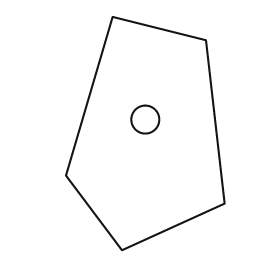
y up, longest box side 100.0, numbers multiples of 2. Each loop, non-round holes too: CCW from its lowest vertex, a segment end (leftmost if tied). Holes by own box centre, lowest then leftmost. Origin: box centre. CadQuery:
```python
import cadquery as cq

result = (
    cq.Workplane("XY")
    .moveTo(-10.0, -50.0)
    .lineTo(34.0, -30.0)
    .lineTo(26.0, 40.0)
    .lineTo(-14.0, 50.0)
    .lineTo(-34.0, -18.0)
    .close()
    .moveTo(0.0, 6.0)
    .circle(6.0)
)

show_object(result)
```